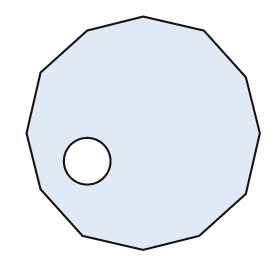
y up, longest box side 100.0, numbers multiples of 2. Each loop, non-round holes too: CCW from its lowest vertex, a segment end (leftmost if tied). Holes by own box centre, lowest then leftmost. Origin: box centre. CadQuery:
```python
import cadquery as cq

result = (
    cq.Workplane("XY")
    .moveTo(0.0, -50.0)
    .lineTo(24.0, -44.0)
    .lineTo(44.0, -26.0)
    .lineTo(50.0, 0.0)
    .lineTo(44.0, 24.0)
    .lineTo(26.0, 44.0)
    .lineTo(0.0, 50.0)
    .lineTo(-24.0, 44.0)
    .lineTo(-44.0, 26.0)
    .lineTo(-50.0, 0.0)
    .lineTo(-44.0, -24.0)
    .lineTo(-26.0, -44.0)
    .close()
    .moveTo(-24.0, -12.0)
    .circle(10.0)
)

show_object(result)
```